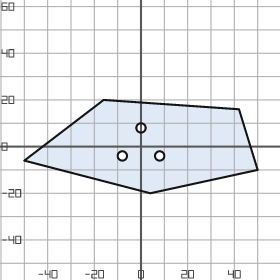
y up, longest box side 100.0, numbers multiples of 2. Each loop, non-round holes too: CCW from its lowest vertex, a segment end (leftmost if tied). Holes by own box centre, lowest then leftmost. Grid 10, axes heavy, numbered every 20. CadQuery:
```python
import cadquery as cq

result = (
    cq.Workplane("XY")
    .moveTo(4.0, -20.0)
    .lineTo(50.0, -10.0)
    .lineTo(42.0, 16.0)
    .lineTo(-16.0, 20.0)
    .lineTo(-50.0, -6.0)
    .close()
    .moveTo(-8.0, -4.0)
    .circle(2.0)
    .moveTo(8.0, -4.0)
    .circle(2.0)
    .moveTo(0.0, 8.0)
    .circle(2.0)
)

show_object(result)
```